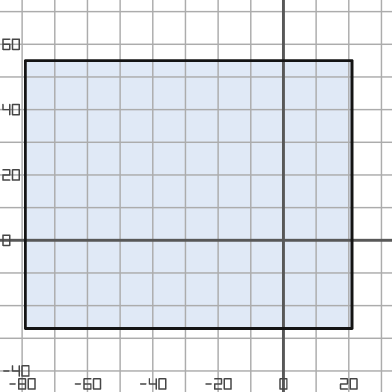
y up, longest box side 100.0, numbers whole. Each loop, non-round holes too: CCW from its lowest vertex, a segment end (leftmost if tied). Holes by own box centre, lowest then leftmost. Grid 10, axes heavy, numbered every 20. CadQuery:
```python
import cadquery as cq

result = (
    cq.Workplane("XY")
    .moveTo(-79.0, -27.0)
    .lineTo(21.0, -27.0)
    .lineTo(21.0, 55.0)
    .lineTo(-79.0, 55.0)
    .close()
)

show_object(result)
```